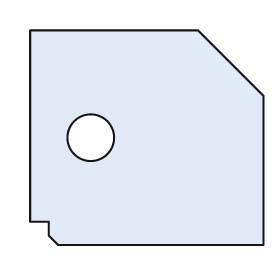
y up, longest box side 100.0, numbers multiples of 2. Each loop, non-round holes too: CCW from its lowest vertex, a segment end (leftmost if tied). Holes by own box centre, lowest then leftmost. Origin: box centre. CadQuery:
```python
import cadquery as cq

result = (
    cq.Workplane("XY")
    .moveTo(-38.0, -46.0)
    .lineTo(50.0, -46.0)
    .lineTo(50.0, 18.0)
    .lineTo(22.0, 46.0)
    .lineTo(-50.0, 46.0)
    .lineTo(-50.0, -36.0)
    .lineTo(-42.0, -36.0)
    .lineTo(-42.0, -42.0)
    .close()
    .moveTo(-24.0, 0.0)
    .circle(10.0)
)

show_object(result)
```